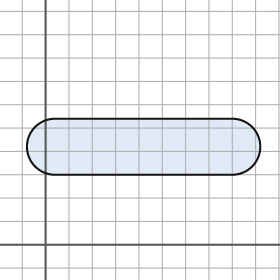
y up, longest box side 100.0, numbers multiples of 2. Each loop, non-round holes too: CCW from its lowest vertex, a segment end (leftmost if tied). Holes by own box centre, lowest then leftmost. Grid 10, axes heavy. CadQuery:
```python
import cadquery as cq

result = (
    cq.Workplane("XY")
    .moveTo(4.0, 30.0)
    .lineTo(80.0, 30.0)
    .threePointArc((92.0, 42.0), (80.0, 54.0))
    .lineTo(4.0, 54.0)
    .threePointArc((-8.0, 42.0), (4.0, 30.0))
    .close()
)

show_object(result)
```